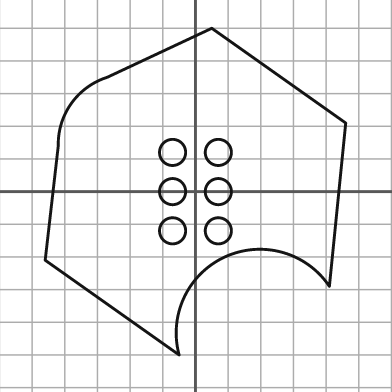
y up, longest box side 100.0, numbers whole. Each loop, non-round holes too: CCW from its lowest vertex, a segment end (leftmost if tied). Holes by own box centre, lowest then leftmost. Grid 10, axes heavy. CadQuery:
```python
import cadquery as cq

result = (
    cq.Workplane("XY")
    .moveTo(-5.0, -50.0)
    .threePointArc((9.0, -20.0), (41.0, -29.0))
    .lineTo(46.0, 21.0)
    .lineTo(5.0, 50.0)
    .lineTo(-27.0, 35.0)
    .threePointArc((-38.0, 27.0), (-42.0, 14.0))
    .lineTo(-46.0, -21.0)
    .close()
    .moveTo(-7.0, -12.0)
    .circle(4.0)
    .moveTo(7.0, -12.0)
    .circle(4.0)
    .moveTo(-7.0, 0.0)
    .circle(4.0)
    .moveTo(7.0, 0.0)
    .circle(4.0)
    .moveTo(-7.0, 12.0)
    .circle(4.0)
    .moveTo(7.0, 12.0)
    .circle(4.0)
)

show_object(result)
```